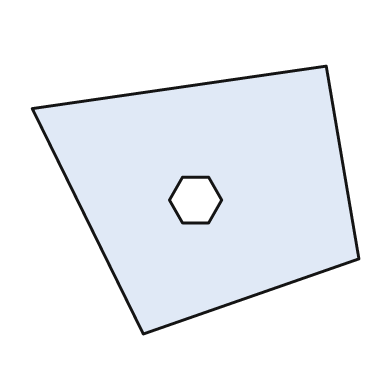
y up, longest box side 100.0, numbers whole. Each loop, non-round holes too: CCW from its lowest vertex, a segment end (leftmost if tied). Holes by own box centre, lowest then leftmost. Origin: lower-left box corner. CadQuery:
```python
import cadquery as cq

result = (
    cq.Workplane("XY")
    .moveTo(34.0, 0.0)
    .lineTo(100.0, 23.0)
    .lineTo(90.0, 82.0)
    .lineTo(0.0, 69.0)
    .close()
    .moveTo(46.0, 34.0)
    .lineTo(54.0, 34.0)
    .lineTo(58.0, 41.0)
    .lineTo(54.0, 48.0)
    .lineTo(46.0, 48.0)
    .lineTo(42.0, 41.0)
    .close()
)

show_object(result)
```